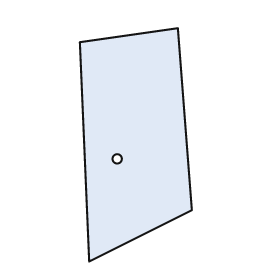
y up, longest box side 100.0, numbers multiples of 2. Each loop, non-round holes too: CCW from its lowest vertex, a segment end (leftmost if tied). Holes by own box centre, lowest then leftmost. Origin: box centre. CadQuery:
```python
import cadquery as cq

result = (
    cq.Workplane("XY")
    .moveTo(-20.0, -50.0)
    .lineTo(24.0, -28.0)
    .lineTo(18.0, 50.0)
    .lineTo(-24.0, 44.0)
    .close()
    .moveTo(-8.0, -6.0)
    .circle(2.0)
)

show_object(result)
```